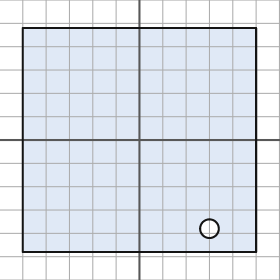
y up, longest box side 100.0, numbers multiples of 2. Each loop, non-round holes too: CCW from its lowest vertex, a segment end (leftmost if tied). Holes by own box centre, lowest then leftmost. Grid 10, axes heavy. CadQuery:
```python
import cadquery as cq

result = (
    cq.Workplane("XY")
    .moveTo(-50.0, -48.0)
    .lineTo(50.0, -48.0)
    .lineTo(50.0, 48.0)
    .lineTo(-50.0, 48.0)
    .close()
    .moveTo(30.0, -38.0)
    .circle(4.0)
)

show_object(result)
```